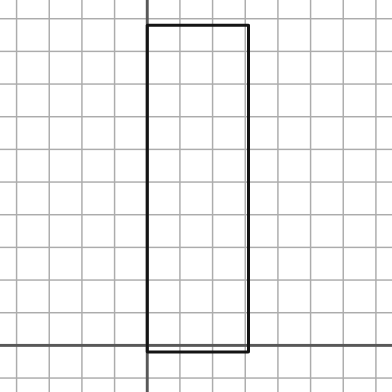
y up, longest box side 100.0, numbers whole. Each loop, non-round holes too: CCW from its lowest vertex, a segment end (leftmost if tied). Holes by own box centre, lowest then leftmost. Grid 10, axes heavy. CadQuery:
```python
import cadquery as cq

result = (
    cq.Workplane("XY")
    .moveTo(0.0, -2.0)
    .lineTo(31.0, -2.0)
    .lineTo(31.0, 98.0)
    .lineTo(0.0, 98.0)
    .close()
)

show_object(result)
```